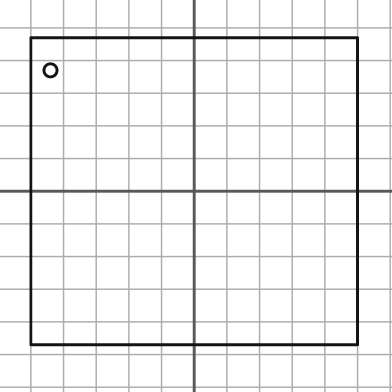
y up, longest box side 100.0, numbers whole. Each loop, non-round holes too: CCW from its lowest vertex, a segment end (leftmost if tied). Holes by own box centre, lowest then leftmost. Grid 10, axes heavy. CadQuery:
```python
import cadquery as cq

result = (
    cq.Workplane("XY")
    .moveTo(-50.0, -47.0)
    .lineTo(50.0, -47.0)
    .lineTo(50.0, 47.0)
    .lineTo(-50.0, 47.0)
    .close()
    .moveTo(-44.0, 37.0)
    .circle(2.0)
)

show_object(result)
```